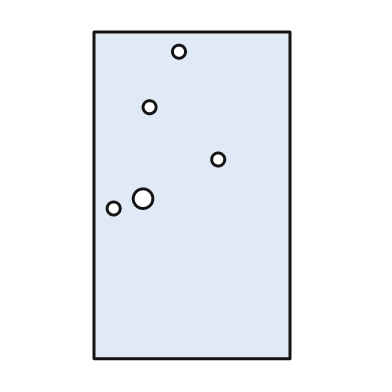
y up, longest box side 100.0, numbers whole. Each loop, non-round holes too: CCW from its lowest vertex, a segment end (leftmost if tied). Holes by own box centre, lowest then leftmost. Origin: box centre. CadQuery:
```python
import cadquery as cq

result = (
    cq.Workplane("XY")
    .moveTo(-30.0, -50.0)
    .lineTo(30.0, -50.0)
    .lineTo(30.0, 50.0)
    .lineTo(-30.0, 50.0)
    .close()
    .moveTo(-24.0, -4.0)
    .circle(2.0)
    .moveTo(-15.0, -1.0)
    .circle(3.0)
    .moveTo(8.0, 11.0)
    .circle(2.0)
    .moveTo(-13.0, 27.0)
    .circle(2.0)
    .moveTo(-4.0, 44.0)
    .circle(2.0)
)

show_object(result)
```